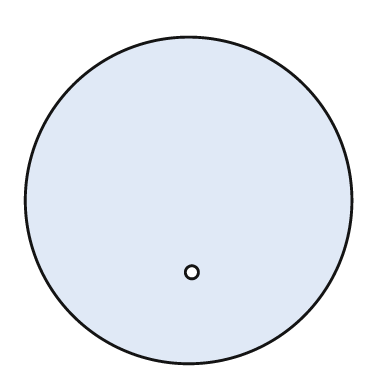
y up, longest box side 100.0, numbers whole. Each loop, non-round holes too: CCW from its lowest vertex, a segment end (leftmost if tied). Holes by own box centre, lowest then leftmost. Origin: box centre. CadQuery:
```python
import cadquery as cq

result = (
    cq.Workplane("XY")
    .moveTo(0.0, 0.0)
    .circle(50.0)
    .moveTo(1.0, -22.0)
    .circle(2.0)
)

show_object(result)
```